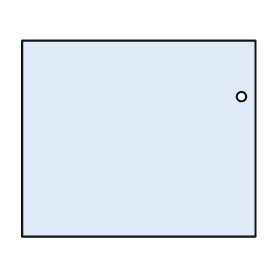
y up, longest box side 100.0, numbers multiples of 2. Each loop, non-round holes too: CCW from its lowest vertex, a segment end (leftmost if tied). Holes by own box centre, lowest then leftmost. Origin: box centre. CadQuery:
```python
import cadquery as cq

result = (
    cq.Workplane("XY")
    .moveTo(-50.0, -42.0)
    .lineTo(50.0, -42.0)
    .lineTo(50.0, 42.0)
    .lineTo(-50.0, 42.0)
    .close()
    .moveTo(44.0, 18.0)
    .circle(2.0)
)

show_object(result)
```